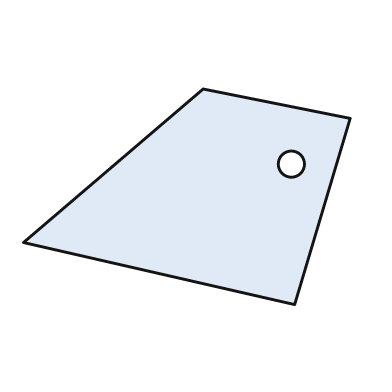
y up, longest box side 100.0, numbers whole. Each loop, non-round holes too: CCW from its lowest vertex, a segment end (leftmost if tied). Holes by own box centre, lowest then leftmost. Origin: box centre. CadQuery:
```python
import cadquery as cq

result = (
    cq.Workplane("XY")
    .moveTo(33.0, -33.0)
    .lineTo(50.0, 24.0)
    .lineTo(5.0, 33.0)
    .lineTo(-50.0, -14.0)
    .close()
    .moveTo(32.0, 10.0)
    .circle(4.0)
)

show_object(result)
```